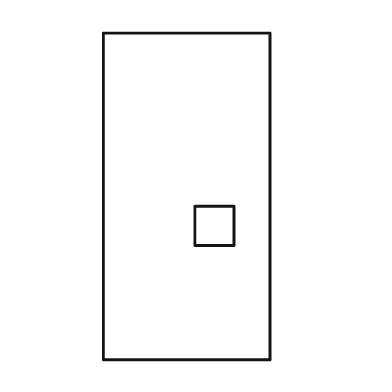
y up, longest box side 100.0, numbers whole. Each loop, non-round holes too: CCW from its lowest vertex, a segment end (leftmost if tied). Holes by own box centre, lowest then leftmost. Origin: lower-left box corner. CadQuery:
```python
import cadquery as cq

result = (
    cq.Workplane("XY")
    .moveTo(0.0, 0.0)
    .lineTo(51.0, 0.0)
    .lineTo(51.0, 100.0)
    .lineTo(0.0, 100.0)
    .close()
    .moveTo(28.0, 35.0)
    .lineTo(40.0, 35.0)
    .lineTo(40.0, 47.0)
    .lineTo(28.0, 47.0)
    .close()
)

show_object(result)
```